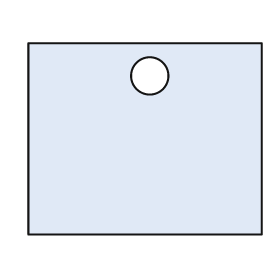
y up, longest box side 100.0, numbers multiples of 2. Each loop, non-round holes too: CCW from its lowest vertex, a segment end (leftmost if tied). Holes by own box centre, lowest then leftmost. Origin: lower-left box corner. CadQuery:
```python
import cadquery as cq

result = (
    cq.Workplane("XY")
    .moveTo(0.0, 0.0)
    .lineTo(100.0, 0.0)
    .lineTo(100.0, 82.0)
    .lineTo(0.0, 82.0)
    .close()
    .moveTo(52.0, 68.0)
    .circle(8.0)
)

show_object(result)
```